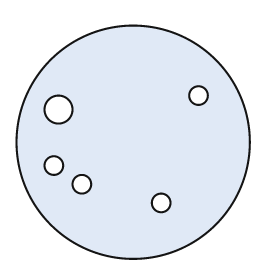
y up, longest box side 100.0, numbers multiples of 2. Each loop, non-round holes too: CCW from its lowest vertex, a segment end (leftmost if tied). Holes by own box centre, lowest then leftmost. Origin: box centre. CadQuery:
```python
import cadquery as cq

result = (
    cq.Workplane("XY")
    .moveTo(0.0, 0.0)
    .circle(50.0)
    .moveTo(12.0, -26.0)
    .circle(4.0)
    .moveTo(-22.0, -18.0)
    .circle(4.0)
    .moveTo(-34.0, -10.0)
    .circle(4.0)
    .moveTo(-32.0, 14.0)
    .circle(6.0)
    .moveTo(28.0, 20.0)
    .circle(4.0)
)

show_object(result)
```